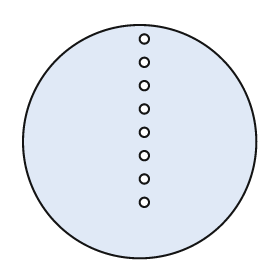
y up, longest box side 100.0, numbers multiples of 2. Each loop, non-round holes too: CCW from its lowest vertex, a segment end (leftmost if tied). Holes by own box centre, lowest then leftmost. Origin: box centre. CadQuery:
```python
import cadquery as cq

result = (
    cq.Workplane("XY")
    .moveTo(0.0, 0.0)
    .circle(50.0)
    .moveTo(2.0, -26.0)
    .circle(2.0)
    .moveTo(2.0, -16.0)
    .circle(2.0)
    .moveTo(2.0, -6.0)
    .circle(2.0)
    .moveTo(2.0, 4.0)
    .circle(2.0)
    .moveTo(2.0, 14.0)
    .circle(2.0)
    .moveTo(2.0, 24.0)
    .circle(2.0)
    .moveTo(2.0, 34.0)
    .circle(2.0)
    .moveTo(2.0, 44.0)
    .circle(2.0)
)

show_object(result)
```